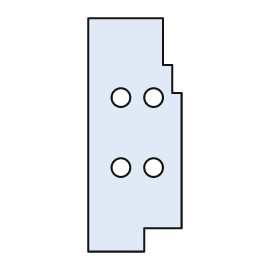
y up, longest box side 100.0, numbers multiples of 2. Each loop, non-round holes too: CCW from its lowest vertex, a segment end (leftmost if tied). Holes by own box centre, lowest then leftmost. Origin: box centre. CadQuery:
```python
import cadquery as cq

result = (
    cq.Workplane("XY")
    .moveTo(-20.0, -50.0)
    .lineTo(4.0, -50.0)
    .lineTo(4.0, -40.0)
    .lineTo(20.0, -40.0)
    .lineTo(20.0, 18.0)
    .lineTo(16.0, 18.0)
    .lineTo(16.0, 30.0)
    .lineTo(12.0, 30.0)
    .lineTo(12.0, 50.0)
    .lineTo(-20.0, 50.0)
    .close()
    .moveTo(-6.0, -14.0)
    .circle(4.0)
    .moveTo(8.0, -14.0)
    .circle(4.0)
    .moveTo(-6.0, 16.0)
    .circle(4.0)
    .moveTo(8.0, 16.0)
    .circle(4.0)
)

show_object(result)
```